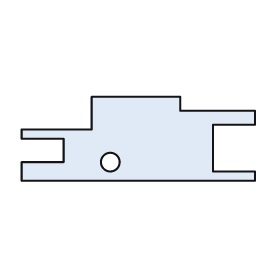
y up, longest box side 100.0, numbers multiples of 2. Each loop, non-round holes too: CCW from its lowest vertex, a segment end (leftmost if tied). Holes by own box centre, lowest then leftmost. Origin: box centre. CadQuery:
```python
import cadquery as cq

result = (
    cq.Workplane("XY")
    .moveTo(-50.0, -18.0)
    .lineTo(50.0, -18.0)
    .lineTo(50.0, -14.0)
    .lineTo(32.0, -14.0)
    .lineTo(32.0, 6.0)
    .lineTo(50.0, 6.0)
    .lineTo(50.0, 12.0)
    .lineTo(18.0, 12.0)
    .lineTo(18.0, 18.0)
    .lineTo(-20.0, 18.0)
    .lineTo(-20.0, 4.0)
    .lineTo(-50.0, 4.0)
    .lineTo(-50.0, 0.0)
    .lineTo(-32.0, 0.0)
    .lineTo(-32.0, -10.0)
    .lineTo(-50.0, -10.0)
    .close()
    .moveTo(-12.0, -10.0)
    .circle(4.0)
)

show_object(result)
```